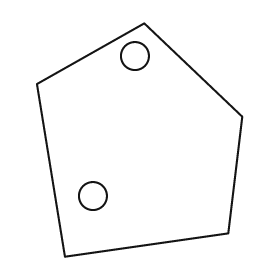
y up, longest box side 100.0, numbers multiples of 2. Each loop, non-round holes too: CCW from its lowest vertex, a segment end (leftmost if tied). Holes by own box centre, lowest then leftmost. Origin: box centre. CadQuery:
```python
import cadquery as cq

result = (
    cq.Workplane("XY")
    .moveTo(-32.0, -50.0)
    .lineTo(38.0, -40.0)
    .lineTo(44.0, 10.0)
    .lineTo(2.0, 50.0)
    .lineTo(-44.0, 24.0)
    .close()
    .moveTo(-20.0, -24.0)
    .circle(6.0)
    .moveTo(-2.0, 36.0)
    .circle(6.0)
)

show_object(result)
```